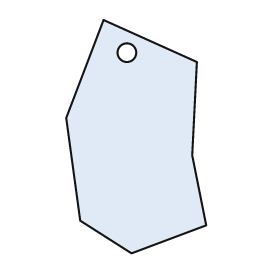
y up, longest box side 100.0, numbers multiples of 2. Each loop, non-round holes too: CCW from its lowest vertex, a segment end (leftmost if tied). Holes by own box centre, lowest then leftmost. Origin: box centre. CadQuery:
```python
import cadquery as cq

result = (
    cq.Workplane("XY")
    .moveTo(-2.0, -50.0)
    .lineTo(30.0, -38.0)
    .lineTo(24.0, -8.0)
    .lineTo(26.0, 32.0)
    .lineTo(-14.0, 50.0)
    .lineTo(-30.0, 8.0)
    .lineTo(-24.0, -36.0)
    .close()
    .moveTo(-4.0, 36.0)
    .circle(4.0)
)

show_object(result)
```